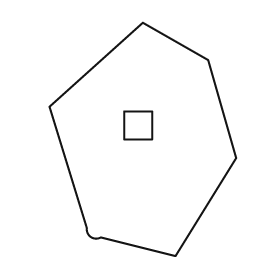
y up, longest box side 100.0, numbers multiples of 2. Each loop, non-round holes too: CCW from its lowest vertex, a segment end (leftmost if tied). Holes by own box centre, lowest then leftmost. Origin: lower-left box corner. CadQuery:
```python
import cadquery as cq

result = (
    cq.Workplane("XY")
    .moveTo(54.0, 0.0)
    .lineTo(80.0, 42.0)
    .lineTo(68.0, 84.0)
    .lineTo(40.0, 100.0)
    .lineTo(0.0, 64.0)
    .lineTo(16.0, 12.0)
    .threePointArc((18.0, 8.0), (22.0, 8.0))
    .close()
    .moveTo(32.0, 50.0)
    .lineTo(44.0, 50.0)
    .lineTo(44.0, 62.0)
    .lineTo(32.0, 62.0)
    .close()
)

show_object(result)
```